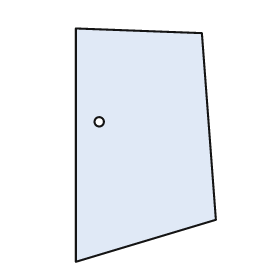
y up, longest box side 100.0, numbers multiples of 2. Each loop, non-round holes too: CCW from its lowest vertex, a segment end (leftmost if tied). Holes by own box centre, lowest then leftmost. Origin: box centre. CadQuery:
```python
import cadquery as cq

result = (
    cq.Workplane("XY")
    .moveTo(-30.0, -50.0)
    .lineTo(30.0, -32.0)
    .lineTo(24.0, 48.0)
    .lineTo(-30.0, 50.0)
    .close()
    .moveTo(-20.0, 10.0)
    .circle(2.0)
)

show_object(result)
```